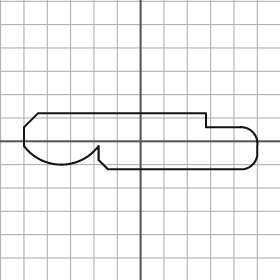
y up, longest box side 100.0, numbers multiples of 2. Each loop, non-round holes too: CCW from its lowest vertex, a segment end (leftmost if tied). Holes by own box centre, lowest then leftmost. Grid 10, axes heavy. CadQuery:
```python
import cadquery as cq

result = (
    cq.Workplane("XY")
    .moveTo(-14.0, -12.0)
    .lineTo(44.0, -12.0)
    .threePointArc((48.0, -10.0), (50.0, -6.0))
    .lineTo(50.0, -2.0)
    .threePointArc((48.0, 4.0), (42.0, 6.0))
    .lineTo(28.0, 6.0)
    .lineTo(28.0, 12.0)
    .lineTo(-44.0, 12.0)
    .lineTo(-50.0, 6.0)
    .lineTo(-50.0, -2.0)
    .threePointArc((-34.0, -10.0), (-18.0, -2.0))
    .lineTo(-18.0, -8.0)
    .close()
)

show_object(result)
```